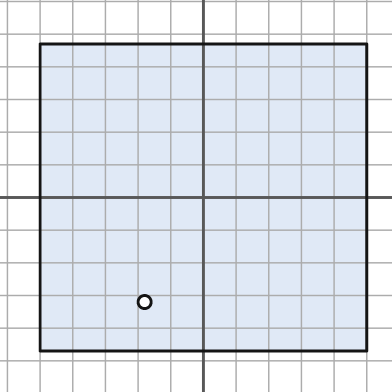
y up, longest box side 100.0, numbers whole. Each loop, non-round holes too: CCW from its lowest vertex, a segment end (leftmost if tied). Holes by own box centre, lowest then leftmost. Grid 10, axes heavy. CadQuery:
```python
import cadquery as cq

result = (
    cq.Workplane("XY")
    .moveTo(-50.0, -47.0)
    .lineTo(50.0, -47.0)
    .lineTo(50.0, 47.0)
    .lineTo(-50.0, 47.0)
    .close()
    .moveTo(-18.0, -32.0)
    .circle(2.0)
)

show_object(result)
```